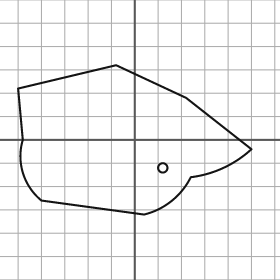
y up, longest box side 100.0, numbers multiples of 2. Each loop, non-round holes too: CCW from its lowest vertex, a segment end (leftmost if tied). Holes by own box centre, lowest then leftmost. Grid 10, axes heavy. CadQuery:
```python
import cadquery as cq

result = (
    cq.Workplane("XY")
    .moveTo(4.0, -32.0)
    .threePointArc((16.0, -26.0), (24.0, -16.0))
    .threePointArc((38.0, -12.0), (50.0, -4.0))
    .lineTo(22.0, 18.0)
    .lineTo(-8.0, 32.0)
    .lineTo(-50.0, 22.0)
    .lineTo(-48.0, 0.0)
    .threePointArc((-48.0, -14.0), (-40.0, -26.0))
    .close()
    .moveTo(12.0, -12.0)
    .circle(2.0)
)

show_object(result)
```